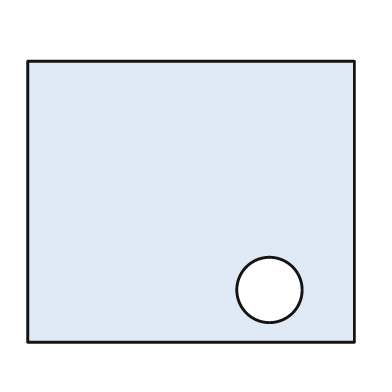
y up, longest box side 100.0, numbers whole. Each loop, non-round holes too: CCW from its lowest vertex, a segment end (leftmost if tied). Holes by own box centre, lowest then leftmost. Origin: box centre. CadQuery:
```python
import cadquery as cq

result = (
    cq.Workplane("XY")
    .moveTo(-50.0, -43.0)
    .lineTo(50.0, -43.0)
    .lineTo(50.0, 43.0)
    .lineTo(-50.0, 43.0)
    .close()
    .moveTo(24.0, -27.0)
    .circle(10.0)
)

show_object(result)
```